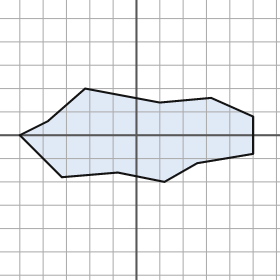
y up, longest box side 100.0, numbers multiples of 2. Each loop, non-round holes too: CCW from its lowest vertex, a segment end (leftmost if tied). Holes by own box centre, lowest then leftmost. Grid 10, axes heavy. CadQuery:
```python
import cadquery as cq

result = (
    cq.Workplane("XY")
    .moveTo(12.0, -20.0)
    .lineTo(26.0, -12.0)
    .lineTo(50.0, -8.0)
    .lineTo(50.0, 8.0)
    .lineTo(32.0, 16.0)
    .lineTo(10.0, 14.0)
    .lineTo(-22.0, 20.0)
    .lineTo(-38.0, 6.0)
    .lineTo(-50.0, 0.0)
    .lineTo(-32.0, -18.0)
    .lineTo(-8.0, -16.0)
    .close()
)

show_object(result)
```